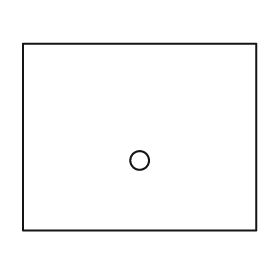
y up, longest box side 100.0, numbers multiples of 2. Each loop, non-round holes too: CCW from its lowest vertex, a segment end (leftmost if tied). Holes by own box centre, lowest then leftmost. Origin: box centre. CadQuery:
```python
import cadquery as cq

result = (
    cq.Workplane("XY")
    .moveTo(-50.0, -40.0)
    .lineTo(50.0, -40.0)
    .lineTo(50.0, 40.0)
    .lineTo(-50.0, 40.0)
    .close()
    .moveTo(0.0, -10.0)
    .circle(4.0)
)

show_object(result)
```